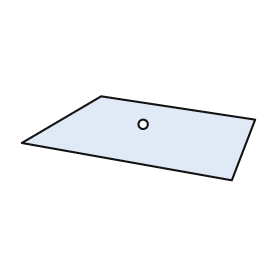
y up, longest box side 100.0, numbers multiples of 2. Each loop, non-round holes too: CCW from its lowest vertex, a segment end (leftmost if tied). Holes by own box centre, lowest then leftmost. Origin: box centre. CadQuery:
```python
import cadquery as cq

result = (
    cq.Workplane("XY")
    .moveTo(40.0, -18.0)
    .lineTo(50.0, 8.0)
    .lineTo(-16.0, 18.0)
    .lineTo(-50.0, -2.0)
    .close()
    .moveTo(2.0, 6.0)
    .circle(2.0)
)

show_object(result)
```